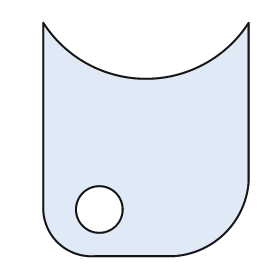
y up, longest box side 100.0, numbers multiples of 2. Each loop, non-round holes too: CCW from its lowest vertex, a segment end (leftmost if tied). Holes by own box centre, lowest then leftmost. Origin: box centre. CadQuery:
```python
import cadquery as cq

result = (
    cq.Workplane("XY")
    .moveTo(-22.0, -50.0)
    .lineTo(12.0, -50.0)
    .threePointArc((34.0, -40.0), (44.0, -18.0))
    .lineTo(44.0, 50.0)
    .threePointArc((0.0, 26.0), (-44.0, 50.0))
    .lineTo(-44.0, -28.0)
    .threePointArc((-38.0, -44.0), (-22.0, -50.0))
    .close()
    .moveTo(-20.0, -30.0)
    .circle(10.0)
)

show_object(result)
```